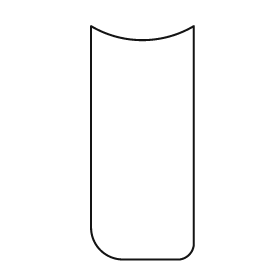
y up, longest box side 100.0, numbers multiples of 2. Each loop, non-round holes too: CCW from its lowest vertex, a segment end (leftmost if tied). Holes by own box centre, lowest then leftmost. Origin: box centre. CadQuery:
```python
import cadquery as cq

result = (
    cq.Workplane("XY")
    .moveTo(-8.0, -50.0)
    .lineTo(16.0, -50.0)
    .threePointArc((20.0, -48.0), (22.0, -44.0))
    .lineTo(22.0, 50.0)
    .threePointArc((0.0, 44.0), (-22.0, 50.0))
    .lineTo(-22.0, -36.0)
    .threePointArc((-18.0, -46.0), (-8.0, -50.0))
    .close()
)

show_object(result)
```